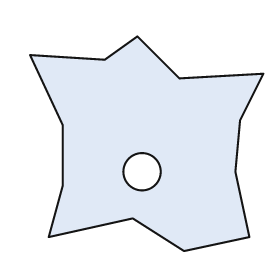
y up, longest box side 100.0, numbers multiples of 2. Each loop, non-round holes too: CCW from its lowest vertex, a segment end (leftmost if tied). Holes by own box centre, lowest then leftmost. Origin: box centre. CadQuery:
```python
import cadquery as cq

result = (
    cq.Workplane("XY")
    .moveTo(16.0, -46.0)
    .lineTo(44.0, -40.0)
    .lineTo(38.0, -12.0)
    .lineTo(40.0, 10.0)
    .lineTo(50.0, 30.0)
    .lineTo(14.0, 28.0)
    .lineTo(-4.0, 46.0)
    .lineTo(-18.0, 36.0)
    .lineTo(-50.0, 38.0)
    .lineTo(-36.0, 8.0)
    .lineTo(-36.0, -18.0)
    .lineTo(-42.0, -40.0)
    .lineTo(-6.0, -32.0)
    .close()
    .moveTo(-2.0, -12.0)
    .circle(8.0)
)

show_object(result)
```